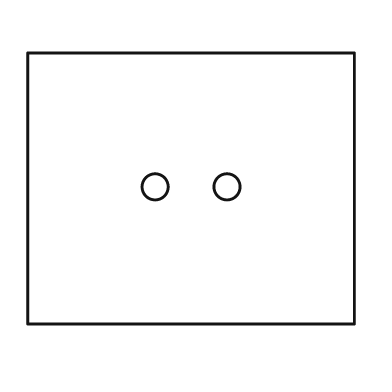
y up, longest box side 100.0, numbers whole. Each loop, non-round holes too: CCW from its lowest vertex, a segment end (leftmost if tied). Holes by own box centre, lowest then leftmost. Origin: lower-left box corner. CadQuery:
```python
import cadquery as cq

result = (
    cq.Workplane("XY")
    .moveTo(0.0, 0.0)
    .lineTo(100.0, 0.0)
    .lineTo(100.0, 83.0)
    .lineTo(0.0, 83.0)
    .close()
    .moveTo(39.0, 42.0)
    .circle(4.0)
    .moveTo(61.0, 42.0)
    .circle(4.0)
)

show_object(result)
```